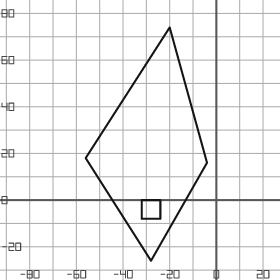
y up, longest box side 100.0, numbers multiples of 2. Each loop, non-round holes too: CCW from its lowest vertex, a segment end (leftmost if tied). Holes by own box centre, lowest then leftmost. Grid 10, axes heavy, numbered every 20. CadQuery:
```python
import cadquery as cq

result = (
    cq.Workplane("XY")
    .moveTo(-28.0, -26.0)
    .lineTo(-4.0, 16.0)
    .lineTo(-20.0, 74.0)
    .lineTo(-56.0, 18.0)
    .close()
    .moveTo(-32.0, -8.0)
    .lineTo(-24.0, -8.0)
    .lineTo(-24.0, 0.0)
    .lineTo(-32.0, 0.0)
    .close()
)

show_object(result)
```